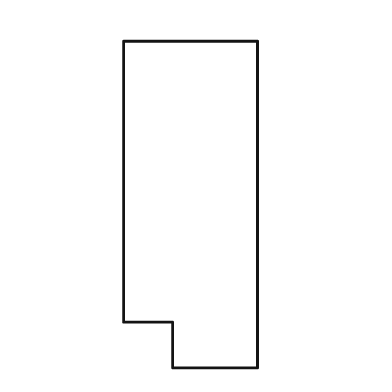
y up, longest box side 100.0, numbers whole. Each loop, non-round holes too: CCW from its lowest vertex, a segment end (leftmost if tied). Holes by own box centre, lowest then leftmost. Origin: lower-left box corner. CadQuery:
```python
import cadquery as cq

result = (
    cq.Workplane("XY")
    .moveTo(15.0, 0.0)
    .lineTo(41.0, 0.0)
    .lineTo(41.0, 100.0)
    .lineTo(0.0, 100.0)
    .lineTo(0.0, 14.0)
    .lineTo(15.0, 14.0)
    .close()
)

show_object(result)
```